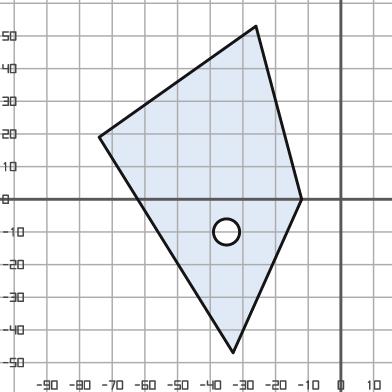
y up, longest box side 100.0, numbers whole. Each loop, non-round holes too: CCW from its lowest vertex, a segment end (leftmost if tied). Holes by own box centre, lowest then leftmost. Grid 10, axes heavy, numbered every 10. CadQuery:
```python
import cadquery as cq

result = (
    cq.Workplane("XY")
    .moveTo(-33.0, -47.0)
    .lineTo(-12.0, 0.0)
    .lineTo(-26.0, 53.0)
    .lineTo(-74.0, 19.0)
    .close()
    .moveTo(-35.0, -10.0)
    .circle(4.0)
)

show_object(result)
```